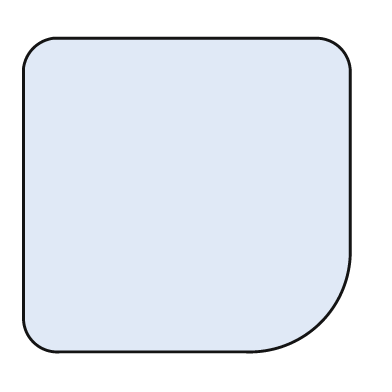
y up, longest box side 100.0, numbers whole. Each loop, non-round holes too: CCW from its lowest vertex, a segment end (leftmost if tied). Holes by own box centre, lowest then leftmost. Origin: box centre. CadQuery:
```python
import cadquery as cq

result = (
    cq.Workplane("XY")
    .moveTo(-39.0, -48.0)
    .lineTo(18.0, -48.0)
    .threePointArc((41.0, -39.0), (50.0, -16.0))
    .lineTo(50.0, 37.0)
    .threePointArc((47.0, 45.0), (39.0, 48.0))
    .lineTo(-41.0, 48.0)
    .threePointArc((-47.0, 45.0), (-50.0, 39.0))
    .lineTo(-50.0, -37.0)
    .threePointArc((-47.0, -45.0), (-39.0, -48.0))
    .close()
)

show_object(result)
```